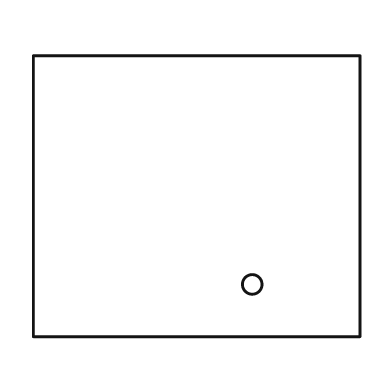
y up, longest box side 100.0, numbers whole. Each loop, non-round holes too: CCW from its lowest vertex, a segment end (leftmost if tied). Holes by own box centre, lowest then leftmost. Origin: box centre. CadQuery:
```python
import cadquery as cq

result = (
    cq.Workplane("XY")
    .moveTo(-50.0, -43.0)
    .lineTo(50.0, -43.0)
    .lineTo(50.0, 43.0)
    .lineTo(-50.0, 43.0)
    .close()
    .moveTo(17.0, -27.0)
    .circle(3.0)
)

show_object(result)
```